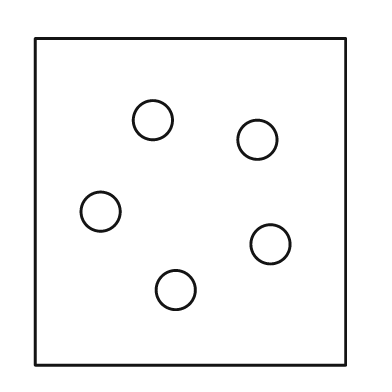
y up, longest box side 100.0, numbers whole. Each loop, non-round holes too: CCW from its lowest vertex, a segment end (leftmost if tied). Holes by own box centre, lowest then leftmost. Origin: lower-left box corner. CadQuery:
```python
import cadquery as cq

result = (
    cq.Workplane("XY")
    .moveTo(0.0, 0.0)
    .lineTo(95.0, 0.0)
    .lineTo(95.0, 100.0)
    .lineTo(0.0, 100.0)
    .close()
    .moveTo(43.0, 23.0)
    .circle(6.0)
    .moveTo(72.0, 37.0)
    .circle(6.0)
    .moveTo(20.0, 47.0)
    .circle(6.0)
    .moveTo(68.0, 69.0)
    .circle(6.0)
    .moveTo(36.0, 75.0)
    .circle(6.0)
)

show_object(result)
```